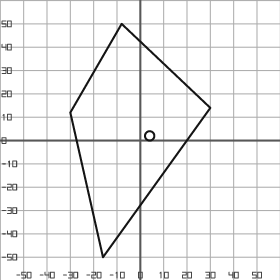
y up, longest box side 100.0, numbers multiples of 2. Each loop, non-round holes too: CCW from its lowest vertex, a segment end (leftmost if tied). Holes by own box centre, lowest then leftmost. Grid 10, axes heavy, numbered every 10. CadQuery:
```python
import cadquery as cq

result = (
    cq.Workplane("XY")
    .moveTo(-16.0, -50.0)
    .lineTo(30.0, 14.0)
    .lineTo(-8.0, 50.0)
    .lineTo(-30.0, 12.0)
    .close()
    .moveTo(4.0, 2.0)
    .circle(2.0)
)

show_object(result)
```